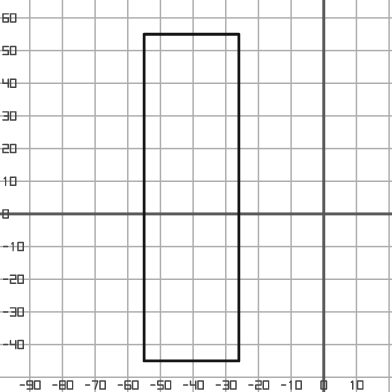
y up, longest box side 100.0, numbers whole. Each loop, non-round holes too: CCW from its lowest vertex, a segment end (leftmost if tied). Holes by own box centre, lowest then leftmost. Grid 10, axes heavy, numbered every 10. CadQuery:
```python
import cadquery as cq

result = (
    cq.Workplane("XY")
    .moveTo(-55.0, -45.0)
    .lineTo(-26.0, -45.0)
    .lineTo(-26.0, 55.0)
    .lineTo(-55.0, 55.0)
    .close()
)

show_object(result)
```